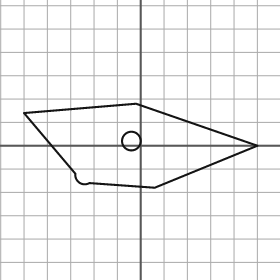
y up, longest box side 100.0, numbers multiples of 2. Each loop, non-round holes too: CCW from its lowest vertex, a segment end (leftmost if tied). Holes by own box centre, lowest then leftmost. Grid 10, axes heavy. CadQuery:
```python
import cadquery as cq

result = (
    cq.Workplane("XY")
    .moveTo(6.0, -18.0)
    .lineTo(50.0, 0.0)
    .lineTo(-2.0, 18.0)
    .lineTo(-50.0, 14.0)
    .lineTo(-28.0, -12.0)
    .threePointArc((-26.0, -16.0), (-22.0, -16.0))
    .close()
    .moveTo(-4.0, 2.0)
    .circle(4.0)
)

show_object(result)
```